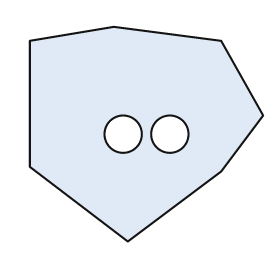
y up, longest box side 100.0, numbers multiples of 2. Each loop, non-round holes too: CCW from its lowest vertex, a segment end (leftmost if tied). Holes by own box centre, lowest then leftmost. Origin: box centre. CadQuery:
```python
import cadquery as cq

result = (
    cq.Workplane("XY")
    .moveTo(-8.0, -46.0)
    .lineTo(32.0, -16.0)
    .lineTo(50.0, 8.0)
    .lineTo(32.0, 40.0)
    .lineTo(-14.0, 46.0)
    .lineTo(-50.0, 40.0)
    .lineTo(-50.0, -14.0)
    .close()
    .moveTo(-10.0, 0.0)
    .circle(8.0)
    .moveTo(10.0, 0.0)
    .circle(8.0)
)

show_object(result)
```